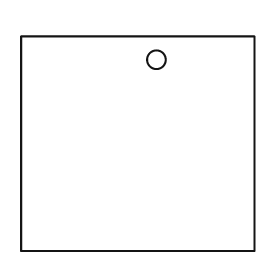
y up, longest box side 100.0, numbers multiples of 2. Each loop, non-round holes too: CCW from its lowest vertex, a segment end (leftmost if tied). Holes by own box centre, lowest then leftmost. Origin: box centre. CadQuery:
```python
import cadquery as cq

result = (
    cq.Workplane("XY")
    .moveTo(-50.0, -46.0)
    .lineTo(50.0, -46.0)
    .lineTo(50.0, 46.0)
    .lineTo(-50.0, 46.0)
    .close()
    .moveTo(8.0, 36.0)
    .circle(4.0)
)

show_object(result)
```